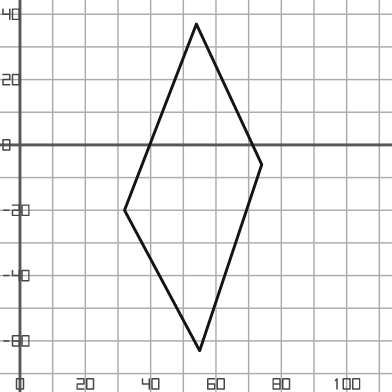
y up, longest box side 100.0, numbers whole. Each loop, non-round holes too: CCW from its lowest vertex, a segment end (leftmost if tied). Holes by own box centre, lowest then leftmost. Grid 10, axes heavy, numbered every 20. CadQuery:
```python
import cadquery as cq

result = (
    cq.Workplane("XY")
    .moveTo(55.0, -63.0)
    .lineTo(74.0, -6.0)
    .lineTo(54.0, 37.0)
    .lineTo(32.0, -20.0)
    .close()
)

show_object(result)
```